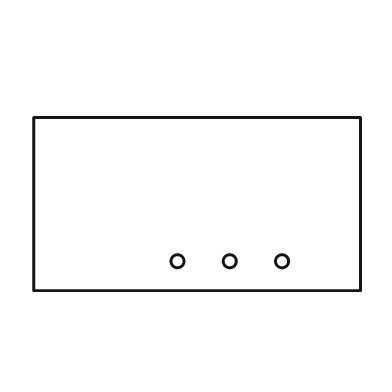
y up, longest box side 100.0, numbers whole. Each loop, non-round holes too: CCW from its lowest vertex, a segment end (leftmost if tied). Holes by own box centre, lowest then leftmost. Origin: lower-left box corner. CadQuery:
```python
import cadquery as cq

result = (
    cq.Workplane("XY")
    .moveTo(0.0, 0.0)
    .lineTo(100.0, 0.0)
    .lineTo(100.0, 53.0)
    .lineTo(0.0, 53.0)
    .close()
    .moveTo(44.0, 9.0)
    .circle(2.0)
    .moveTo(60.0, 9.0)
    .circle(2.0)
    .moveTo(76.0, 9.0)
    .circle(2.0)
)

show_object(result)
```